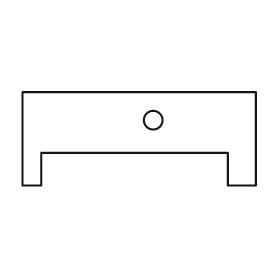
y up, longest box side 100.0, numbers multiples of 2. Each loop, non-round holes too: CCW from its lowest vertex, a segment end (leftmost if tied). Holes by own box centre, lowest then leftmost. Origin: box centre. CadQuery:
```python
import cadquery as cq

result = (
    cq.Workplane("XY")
    .moveTo(-50.0, -20.0)
    .lineTo(-42.0, -20.0)
    .lineTo(-42.0, -6.0)
    .lineTo(38.0, -6.0)
    .lineTo(38.0, -20.0)
    .lineTo(50.0, -20.0)
    .lineTo(50.0, 20.0)
    .lineTo(-50.0, 20.0)
    .close()
    .moveTo(6.0, 8.0)
    .circle(4.0)
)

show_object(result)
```